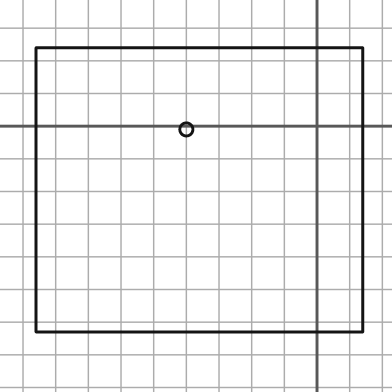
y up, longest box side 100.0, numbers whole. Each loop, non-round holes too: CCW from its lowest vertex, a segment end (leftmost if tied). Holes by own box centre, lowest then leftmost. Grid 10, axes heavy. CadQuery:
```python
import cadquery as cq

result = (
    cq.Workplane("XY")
    .moveTo(-86.0, -63.0)
    .lineTo(14.0, -63.0)
    .lineTo(14.0, 24.0)
    .lineTo(-86.0, 24.0)
    .close()
    .moveTo(-40.0, -1.0)
    .circle(2.0)
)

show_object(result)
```